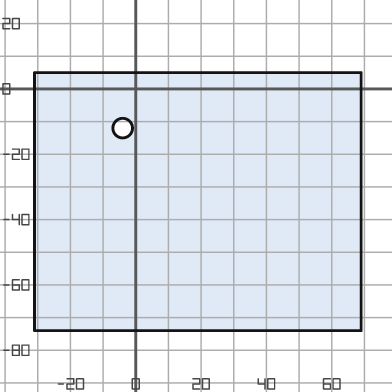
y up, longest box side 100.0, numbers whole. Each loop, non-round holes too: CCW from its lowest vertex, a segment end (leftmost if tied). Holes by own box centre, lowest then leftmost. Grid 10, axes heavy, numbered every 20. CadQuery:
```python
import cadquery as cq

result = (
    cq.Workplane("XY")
    .moveTo(-31.0, -74.0)
    .lineTo(69.0, -74.0)
    .lineTo(69.0, 5.0)
    .lineTo(-31.0, 5.0)
    .close()
    .moveTo(-4.0, -12.0)
    .circle(3.0)
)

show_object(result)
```